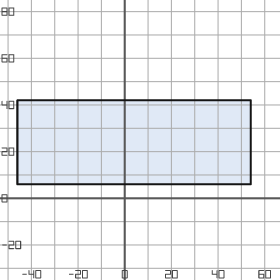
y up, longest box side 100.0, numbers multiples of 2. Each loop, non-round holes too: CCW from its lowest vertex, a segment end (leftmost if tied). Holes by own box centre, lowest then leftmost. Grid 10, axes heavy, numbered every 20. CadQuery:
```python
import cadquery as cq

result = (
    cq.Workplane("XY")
    .moveTo(-46.0, 6.0)
    .lineTo(54.0, 6.0)
    .lineTo(54.0, 42.0)
    .lineTo(-46.0, 42.0)
    .close()
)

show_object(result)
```